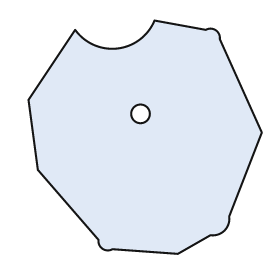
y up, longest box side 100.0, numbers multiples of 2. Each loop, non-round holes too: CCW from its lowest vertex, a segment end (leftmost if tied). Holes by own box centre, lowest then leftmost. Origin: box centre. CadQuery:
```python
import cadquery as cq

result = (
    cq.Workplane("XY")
    .moveTo(14.0, -50.0)
    .lineTo(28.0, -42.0)
    .threePointArc((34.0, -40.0), (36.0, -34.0))
    .lineTo(50.0, 2.0)
    .lineTo(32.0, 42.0)
    .threePointArc((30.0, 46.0), (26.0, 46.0))
    .lineTo(4.0, 50.0)
    .threePointArc((-12.0, 38.0), (-30.0, 46.0))
    .lineTo(-50.0, 16.0)
    .lineTo(-46.0, -14.0)
    .lineTo(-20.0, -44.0)
    .threePointArc((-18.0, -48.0), (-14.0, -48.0))
    .close()
    .moveTo(-2.0, 10.0)
    .circle(4.0)
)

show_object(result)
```